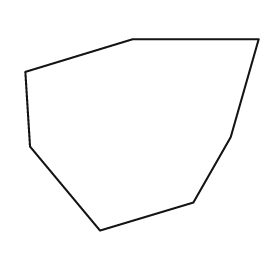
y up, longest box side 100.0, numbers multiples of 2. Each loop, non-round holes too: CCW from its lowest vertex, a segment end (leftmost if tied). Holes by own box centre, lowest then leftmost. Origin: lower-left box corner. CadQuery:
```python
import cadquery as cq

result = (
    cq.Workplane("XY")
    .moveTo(32.0, 0.0)
    .lineTo(72.0, 12.0)
    .lineTo(88.0, 40.0)
    .lineTo(100.0, 82.0)
    .lineTo(46.0, 82.0)
    .lineTo(0.0, 68.0)
    .lineTo(2.0, 36.0)
    .close()
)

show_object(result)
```